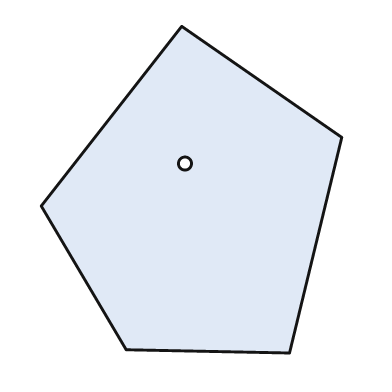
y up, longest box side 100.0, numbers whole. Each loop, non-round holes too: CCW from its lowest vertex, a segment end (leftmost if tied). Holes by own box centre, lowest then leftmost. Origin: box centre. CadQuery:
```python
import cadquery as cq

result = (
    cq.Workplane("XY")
    .moveTo(30.0, -50.0)
    .lineTo(46.0, 16.0)
    .lineTo(-3.0, 50.0)
    .lineTo(-46.0, -5.0)
    .lineTo(-20.0, -49.0)
    .close()
    .moveTo(-2.0, 8.0)
    .circle(2.0)
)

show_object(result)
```